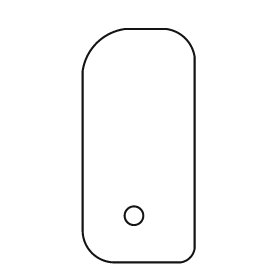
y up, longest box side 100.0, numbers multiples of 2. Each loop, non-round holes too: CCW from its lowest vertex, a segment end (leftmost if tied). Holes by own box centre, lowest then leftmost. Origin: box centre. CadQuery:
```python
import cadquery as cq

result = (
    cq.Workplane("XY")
    .moveTo(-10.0, -50.0)
    .lineTo(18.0, -50.0)
    .threePointArc((22.0, -48.0), (24.0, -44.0))
    .lineTo(24.0, 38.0)
    .threePointArc((20.0, 46.0), (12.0, 50.0))
    .lineTo(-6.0, 50.0)
    .threePointArc((-18.0, 44.0), (-24.0, 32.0))
    .lineTo(-24.0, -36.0)
    .threePointArc((-20.0, -46.0), (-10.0, -50.0))
    .close()
    .moveTo(-2.0, -30.0)
    .circle(4.0)
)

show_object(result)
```